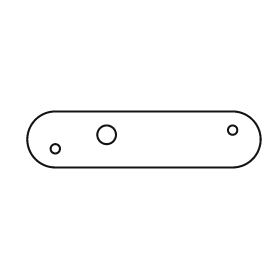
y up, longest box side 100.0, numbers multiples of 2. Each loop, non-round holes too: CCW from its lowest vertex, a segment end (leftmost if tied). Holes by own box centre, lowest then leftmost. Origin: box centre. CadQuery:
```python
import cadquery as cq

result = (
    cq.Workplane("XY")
    .moveTo(-38.0, -12.0)
    .lineTo(38.0, -12.0)
    .threePointArc((50.0, 0.0), (38.0, 12.0))
    .lineTo(-38.0, 12.0)
    .threePointArc((-50.0, 0.0), (-38.0, -12.0))
    .close()
    .moveTo(-38.0, -4.0)
    .circle(2.0)
    .moveTo(-16.0, 2.0)
    .circle(4.0)
    .moveTo(38.0, 4.0)
    .circle(2.0)
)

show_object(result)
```